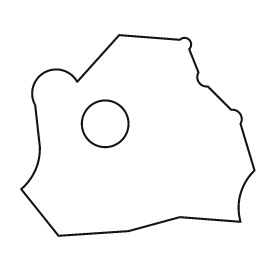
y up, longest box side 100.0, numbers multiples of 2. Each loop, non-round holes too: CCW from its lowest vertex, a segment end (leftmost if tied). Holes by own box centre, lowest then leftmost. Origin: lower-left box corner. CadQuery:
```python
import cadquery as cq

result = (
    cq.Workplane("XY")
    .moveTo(16.0, 0.0)
    .lineTo(46.0, 2.0)
    .lineTo(68.0, 8.0)
    .lineTo(94.0, 6.0)
    .threePointArc((94.0, 18.0), (100.0, 28.0))
    .lineTo(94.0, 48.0)
    .threePointArc((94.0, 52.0), (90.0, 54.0))
    .lineTo(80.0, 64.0)
    .threePointArc((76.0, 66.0), (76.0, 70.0))
    .lineTo(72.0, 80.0)
    .threePointArc((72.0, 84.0), (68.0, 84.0))
    .lineTo(42.0, 86.0)
    .lineTo(24.0, 66.0)
    .threePointArc((10.0, 70.0), (6.0, 56.0))
    .lineTo(8.0, 38.0)
    .threePointArc((6.0, 28.0), (0.0, 20.0))
    .close()
    .moveTo(36.0, 48.0)
    .circle(10.0)
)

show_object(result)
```